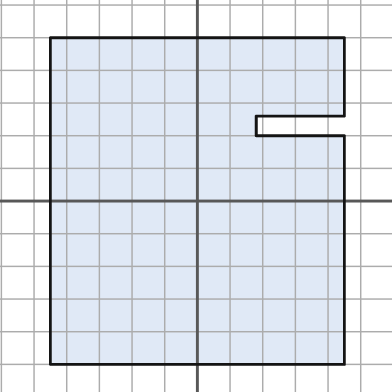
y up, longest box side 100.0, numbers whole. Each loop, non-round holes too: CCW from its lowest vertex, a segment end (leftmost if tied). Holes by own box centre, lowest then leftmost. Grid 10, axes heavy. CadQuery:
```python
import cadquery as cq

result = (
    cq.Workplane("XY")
    .moveTo(-45.0, -50.0)
    .lineTo(45.0, -50.0)
    .lineTo(45.0, 20.0)
    .lineTo(18.0, 20.0)
    .lineTo(18.0, 26.0)
    .lineTo(45.0, 26.0)
    .lineTo(45.0, 50.0)
    .lineTo(-45.0, 50.0)
    .close()
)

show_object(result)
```